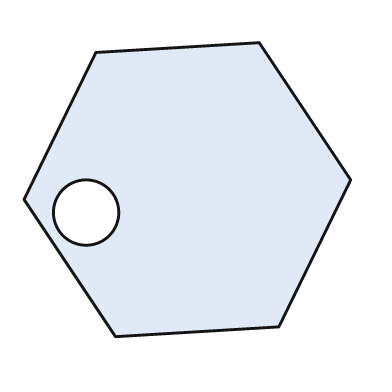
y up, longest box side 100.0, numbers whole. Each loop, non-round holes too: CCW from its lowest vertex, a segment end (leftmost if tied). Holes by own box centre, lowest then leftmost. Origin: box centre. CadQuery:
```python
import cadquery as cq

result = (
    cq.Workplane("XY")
    .moveTo(-22.0, -45.0)
    .lineTo(28.0, -42.0)
    .lineTo(50.0, 3.0)
    .lineTo(22.0, 45.0)
    .lineTo(-28.0, 42.0)
    .lineTo(-50.0, -3.0)
    .close()
    .moveTo(-31.0, -7.0)
    .circle(10.0)
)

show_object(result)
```